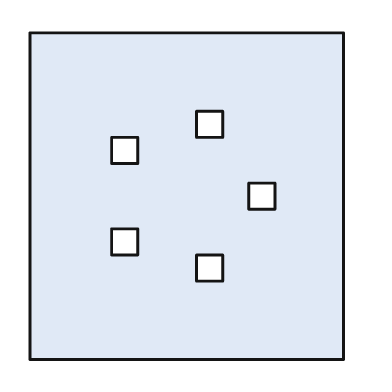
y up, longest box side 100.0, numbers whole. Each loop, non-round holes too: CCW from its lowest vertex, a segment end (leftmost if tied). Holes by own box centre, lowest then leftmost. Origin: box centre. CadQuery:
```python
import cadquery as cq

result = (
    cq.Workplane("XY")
    .moveTo(-48.0, -50.0)
    .lineTo(48.0, -50.0)
    .lineTo(48.0, 50.0)
    .lineTo(-48.0, 50.0)
    .close()
    .moveTo(3.0, -26.0)
    .lineTo(11.0, -26.0)
    .lineTo(11.0, -18.0)
    .lineTo(3.0, -18.0)
    .close()
    .moveTo(-23.0, -18.0)
    .lineTo(-15.0, -18.0)
    .lineTo(-15.0, -10.0)
    .lineTo(-23.0, -10.0)
    .close()
    .moveTo(19.0, -4.0)
    .lineTo(27.0, -4.0)
    .lineTo(27.0, 4.0)
    .lineTo(19.0, 4.0)
    .close()
    .moveTo(-23.0, 10.0)
    .lineTo(-15.0, 10.0)
    .lineTo(-15.0, 18.0)
    .lineTo(-23.0, 18.0)
    .close()
    .moveTo(3.0, 18.0)
    .lineTo(11.0, 18.0)
    .lineTo(11.0, 26.0)
    .lineTo(3.0, 26.0)
    .close()
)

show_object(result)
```